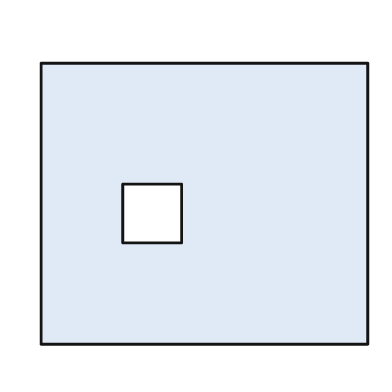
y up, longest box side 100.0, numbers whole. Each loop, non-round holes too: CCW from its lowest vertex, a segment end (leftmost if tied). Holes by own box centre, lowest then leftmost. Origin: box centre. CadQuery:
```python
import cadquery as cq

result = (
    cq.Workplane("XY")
    .moveTo(-50.0, -43.0)
    .lineTo(50.0, -43.0)
    .lineTo(50.0, 43.0)
    .lineTo(-50.0, 43.0)
    .close()
    .moveTo(-25.0, -12.0)
    .lineTo(-7.0, -12.0)
    .lineTo(-7.0, 6.0)
    .lineTo(-25.0, 6.0)
    .close()
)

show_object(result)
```